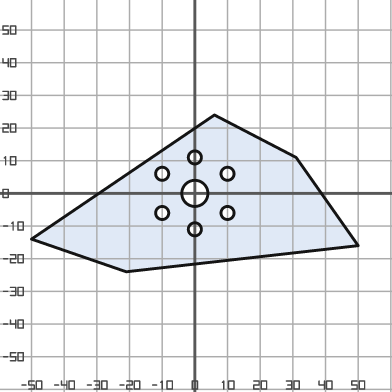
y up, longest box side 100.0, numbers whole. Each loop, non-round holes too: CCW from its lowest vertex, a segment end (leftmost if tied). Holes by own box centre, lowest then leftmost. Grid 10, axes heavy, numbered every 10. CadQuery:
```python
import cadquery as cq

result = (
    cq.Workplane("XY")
    .moveTo(-21.0, -24.0)
    .lineTo(50.0, -16.0)
    .lineTo(31.0, 11.0)
    .lineTo(6.0, 24.0)
    .lineTo(-50.0, -14.0)
    .close()
    .moveTo(0.0, -11.0)
    .circle(2.0)
    .moveTo(-10.0, -6.0)
    .circle(2.0)
    .moveTo(10.0, -6.0)
    .circle(2.0)
    .moveTo(0.0, 0.0)
    .circle(4.0)
    .moveTo(-10.0, 6.0)
    .circle(2.0)
    .moveTo(10.0, 6.0)
    .circle(2.0)
    .moveTo(0.0, 11.0)
    .circle(2.0)
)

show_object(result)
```